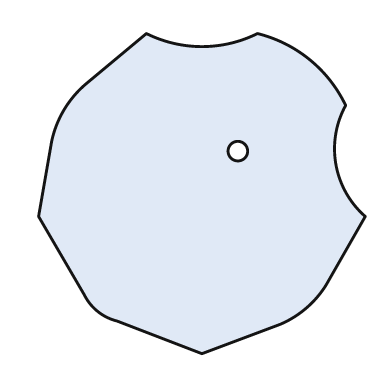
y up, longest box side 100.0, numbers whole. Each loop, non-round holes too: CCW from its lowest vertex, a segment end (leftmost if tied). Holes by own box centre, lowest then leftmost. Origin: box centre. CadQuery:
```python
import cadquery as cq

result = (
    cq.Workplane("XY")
    .moveTo(0.0, -49.0)
    .lineTo(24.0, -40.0)
    .threePointArc((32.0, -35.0), (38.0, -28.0))
    .lineTo(50.0, -7.0)
    .threePointArc((41.0, 9.0), (44.0, 27.0))
    .threePointArc((33.0, 41.0), (17.0, 49.0))
    .threePointArc((0.0, 45.0), (-17.0, 49.0))
    .lineTo(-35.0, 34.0)
    .threePointArc((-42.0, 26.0), (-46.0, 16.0))
    .lineTo(-50.0, -7.0)
    .lineTo(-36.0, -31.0)
    .threePointArc((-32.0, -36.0), (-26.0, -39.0))
    .close()
    .moveTo(11.0, 13.0)
    .circle(3.0)
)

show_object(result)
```